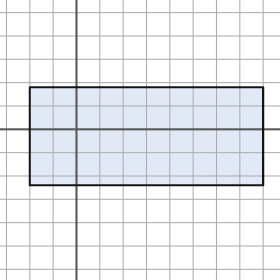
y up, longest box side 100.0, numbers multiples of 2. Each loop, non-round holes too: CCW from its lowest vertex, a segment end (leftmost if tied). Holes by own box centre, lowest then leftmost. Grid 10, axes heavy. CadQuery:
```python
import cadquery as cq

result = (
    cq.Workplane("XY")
    .moveTo(-20.0, -24.0)
    .lineTo(80.0, -24.0)
    .lineTo(80.0, 18.0)
    .lineTo(-20.0, 18.0)
    .close()
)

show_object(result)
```